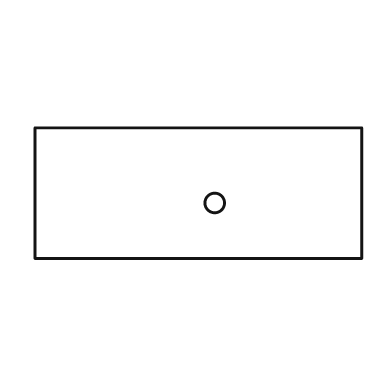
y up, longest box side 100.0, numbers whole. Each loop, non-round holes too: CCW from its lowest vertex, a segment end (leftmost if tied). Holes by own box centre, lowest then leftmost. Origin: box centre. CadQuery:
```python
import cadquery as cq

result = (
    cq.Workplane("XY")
    .moveTo(-50.0, -20.0)
    .lineTo(50.0, -20.0)
    .lineTo(50.0, 20.0)
    .lineTo(-50.0, 20.0)
    .close()
    .moveTo(5.0, -3.0)
    .circle(3.0)
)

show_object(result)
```